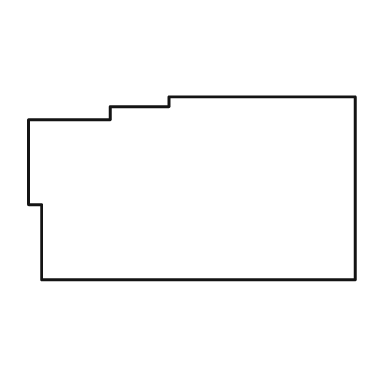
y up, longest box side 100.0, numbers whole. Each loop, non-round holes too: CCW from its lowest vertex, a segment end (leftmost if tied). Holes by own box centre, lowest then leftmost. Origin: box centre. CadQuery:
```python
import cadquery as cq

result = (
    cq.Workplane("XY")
    .moveTo(-46.0, -28.0)
    .lineTo(50.0, -28.0)
    .lineTo(50.0, 28.0)
    .lineTo(-7.0, 28.0)
    .lineTo(-7.0, 25.0)
    .lineTo(-25.0, 25.0)
    .lineTo(-25.0, 21.0)
    .lineTo(-50.0, 21.0)
    .lineTo(-50.0, -5.0)
    .lineTo(-46.0, -5.0)
    .close()
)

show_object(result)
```